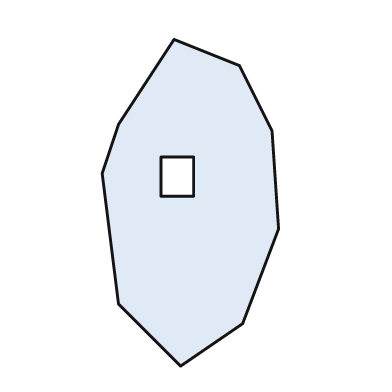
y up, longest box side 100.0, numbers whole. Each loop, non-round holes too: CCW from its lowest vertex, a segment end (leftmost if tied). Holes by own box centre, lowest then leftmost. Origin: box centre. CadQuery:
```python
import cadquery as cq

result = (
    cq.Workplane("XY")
    .moveTo(-3.0, -50.0)
    .lineTo(16.0, -37.0)
    .lineTo(27.0, -8.0)
    .lineTo(25.0, 22.0)
    .lineTo(15.0, 42.0)
    .lineTo(-5.0, 50.0)
    .lineTo(-22.0, 24.0)
    .lineTo(-27.0, 9.0)
    .lineTo(-22.0, -31.0)
    .close()
    .moveTo(-9.0, 2.0)
    .lineTo(1.0, 2.0)
    .lineTo(1.0, 14.0)
    .lineTo(-9.0, 14.0)
    .close()
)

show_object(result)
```